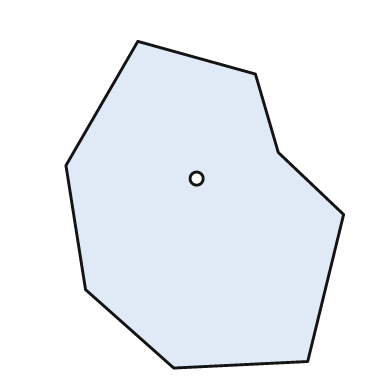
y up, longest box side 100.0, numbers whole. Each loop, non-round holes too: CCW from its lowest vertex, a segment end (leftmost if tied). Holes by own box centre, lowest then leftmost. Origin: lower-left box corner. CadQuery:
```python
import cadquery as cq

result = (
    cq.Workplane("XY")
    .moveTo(33.0, 0.0)
    .lineTo(74.0, 2.0)
    .lineTo(85.0, 47.0)
    .lineTo(65.0, 66.0)
    .lineTo(58.0, 90.0)
    .lineTo(22.0, 100.0)
    .lineTo(0.0, 62.0)
    .lineTo(6.0, 24.0)
    .close()
    .moveTo(40.0, 58.0)
    .circle(2.0)
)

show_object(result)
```